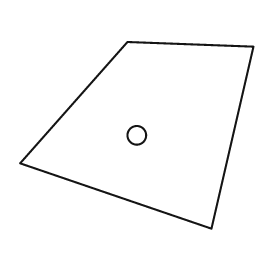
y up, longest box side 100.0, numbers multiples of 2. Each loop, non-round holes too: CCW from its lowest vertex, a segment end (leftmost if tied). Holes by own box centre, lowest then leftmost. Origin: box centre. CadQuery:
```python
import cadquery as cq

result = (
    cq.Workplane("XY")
    .moveTo(32.0, -40.0)
    .lineTo(50.0, 38.0)
    .lineTo(-4.0, 40.0)
    .lineTo(-50.0, -12.0)
    .close()
    .moveTo(0.0, 0.0)
    .circle(4.0)
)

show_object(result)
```